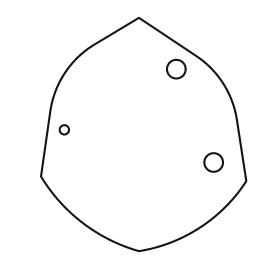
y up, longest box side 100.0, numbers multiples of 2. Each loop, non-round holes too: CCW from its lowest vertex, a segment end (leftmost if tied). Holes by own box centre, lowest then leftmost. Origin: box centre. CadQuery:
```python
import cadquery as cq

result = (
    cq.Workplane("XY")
    .moveTo(-2.0, -50.0)
    .threePointArc((24.0, -40.0), (44.0, -20.0))
    .lineTo(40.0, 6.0)
    .threePointArc((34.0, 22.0), (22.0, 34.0))
    .lineTo(-2.0, 50.0)
    .lineTo(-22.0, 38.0)
    .threePointArc((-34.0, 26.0), (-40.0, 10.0))
    .lineTo(-44.0, -18.0)
    .threePointArc((-26.0, -38.0), (-2.0, -50.0))
    .close()
    .moveTo(30.0, -12.0)
    .circle(4.0)
    .moveTo(-34.0, 2.0)
    .circle(2.0)
    .moveTo(14.0, 28.0)
    .circle(4.0)
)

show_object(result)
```